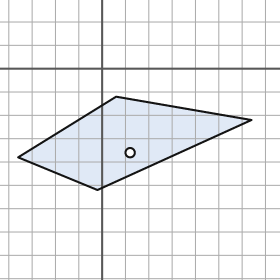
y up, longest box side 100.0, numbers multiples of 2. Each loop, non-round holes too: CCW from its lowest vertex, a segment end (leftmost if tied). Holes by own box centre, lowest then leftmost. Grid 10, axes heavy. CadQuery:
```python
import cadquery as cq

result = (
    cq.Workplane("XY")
    .moveTo(-2.0, -52.0)
    .lineTo(64.0, -22.0)
    .lineTo(6.0, -12.0)
    .lineTo(-36.0, -38.0)
    .close()
    .moveTo(12.0, -36.0)
    .circle(2.0)
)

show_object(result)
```